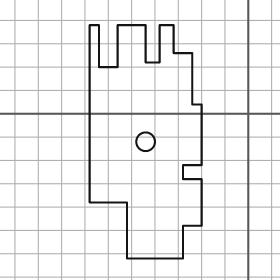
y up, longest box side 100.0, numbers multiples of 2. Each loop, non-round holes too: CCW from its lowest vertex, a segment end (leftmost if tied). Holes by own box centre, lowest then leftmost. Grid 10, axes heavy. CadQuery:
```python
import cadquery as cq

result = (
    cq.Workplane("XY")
    .moveTo(-52.0, -62.0)
    .lineTo(-28.0, -62.0)
    .lineTo(-28.0, -48.0)
    .lineTo(-20.0, -48.0)
    .lineTo(-20.0, -28.0)
    .lineTo(-28.0, -28.0)
    .lineTo(-28.0, -22.0)
    .lineTo(-20.0, -22.0)
    .lineTo(-20.0, 4.0)
    .lineTo(-24.0, 4.0)
    .lineTo(-24.0, 26.0)
    .lineTo(-32.0, 26.0)
    .lineTo(-32.0, 38.0)
    .lineTo(-38.0, 38.0)
    .lineTo(-38.0, 22.0)
    .lineTo(-44.0, 22.0)
    .lineTo(-44.0, 38.0)
    .lineTo(-56.0, 38.0)
    .lineTo(-56.0, 20.0)
    .lineTo(-64.0, 20.0)
    .lineTo(-64.0, 38.0)
    .lineTo(-68.0, 38.0)
    .lineTo(-68.0, -38.0)
    .lineTo(-52.0, -38.0)
    .close()
    .moveTo(-44.0, -12.0)
    .circle(4.0)
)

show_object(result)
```